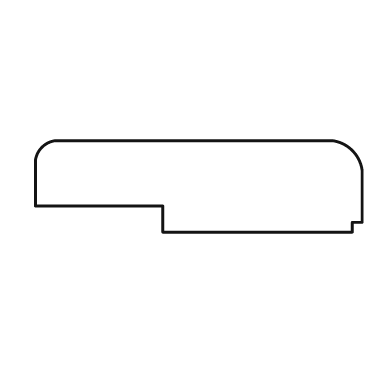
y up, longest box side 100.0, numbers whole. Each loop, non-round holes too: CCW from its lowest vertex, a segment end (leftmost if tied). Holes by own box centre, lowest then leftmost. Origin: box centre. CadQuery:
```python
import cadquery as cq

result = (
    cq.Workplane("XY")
    .moveTo(-11.0, -14.0)
    .lineTo(47.0, -14.0)
    .lineTo(47.0, -11.0)
    .lineTo(50.0, -11.0)
    .lineTo(50.0, 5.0)
    .threePointArc((47.0, 11.0), (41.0, 14.0))
    .lineTo(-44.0, 14.0)
    .threePointArc((-48.0, 12.0), (-50.0, 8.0))
    .lineTo(-50.0, -6.0)
    .lineTo(-11.0, -6.0)
    .close()
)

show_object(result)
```